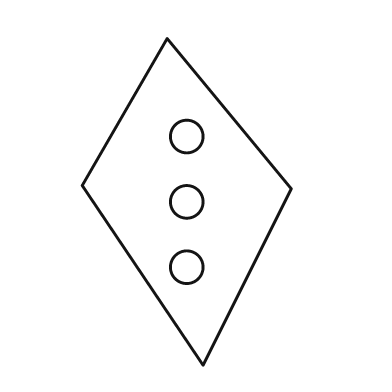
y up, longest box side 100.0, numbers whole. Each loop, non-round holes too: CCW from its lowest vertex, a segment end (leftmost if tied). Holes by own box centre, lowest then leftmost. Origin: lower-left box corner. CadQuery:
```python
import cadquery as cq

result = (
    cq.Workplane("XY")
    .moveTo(37.0, 0.0)
    .lineTo(64.0, 54.0)
    .lineTo(26.0, 100.0)
    .lineTo(0.0, 55.0)
    .close()
    .moveTo(32.0, 30.0)
    .circle(5.0)
    .moveTo(32.0, 50.0)
    .circle(5.0)
    .moveTo(32.0, 70.0)
    .circle(5.0)
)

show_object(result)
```